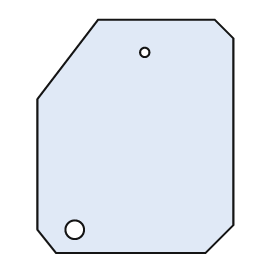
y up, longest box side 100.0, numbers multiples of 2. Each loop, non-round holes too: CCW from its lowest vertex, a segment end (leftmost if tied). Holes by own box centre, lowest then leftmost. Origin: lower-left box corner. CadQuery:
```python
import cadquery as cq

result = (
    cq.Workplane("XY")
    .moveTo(8.0, 0.0)
    .lineTo(72.0, 0.0)
    .lineTo(84.0, 12.0)
    .lineTo(84.0, 92.0)
    .lineTo(76.0, 100.0)
    .lineTo(26.0, 100.0)
    .lineTo(0.0, 66.0)
    .lineTo(0.0, 10.0)
    .close()
    .moveTo(16.0, 10.0)
    .circle(4.0)
    .moveTo(46.0, 86.0)
    .circle(2.0)
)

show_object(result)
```